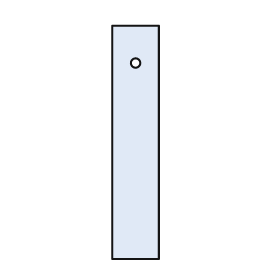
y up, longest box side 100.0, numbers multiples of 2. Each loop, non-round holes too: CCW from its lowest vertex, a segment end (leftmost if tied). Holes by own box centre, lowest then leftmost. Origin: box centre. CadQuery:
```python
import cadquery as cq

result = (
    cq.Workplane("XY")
    .moveTo(-10.0, -50.0)
    .lineTo(10.0, -50.0)
    .lineTo(10.0, 50.0)
    .lineTo(-10.0, 50.0)
    .close()
    .moveTo(0.0, 34.0)
    .circle(2.0)
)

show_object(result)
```